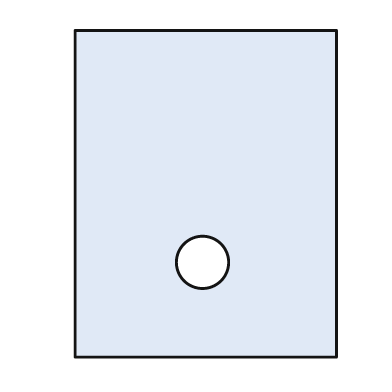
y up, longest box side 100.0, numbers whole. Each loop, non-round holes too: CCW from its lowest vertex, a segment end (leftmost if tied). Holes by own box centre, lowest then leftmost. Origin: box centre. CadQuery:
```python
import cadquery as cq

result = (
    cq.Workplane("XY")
    .moveTo(-40.0, -50.0)
    .lineTo(40.0, -50.0)
    .lineTo(40.0, 50.0)
    .lineTo(-40.0, 50.0)
    .close()
    .moveTo(-1.0, -21.0)
    .circle(8.0)
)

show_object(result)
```